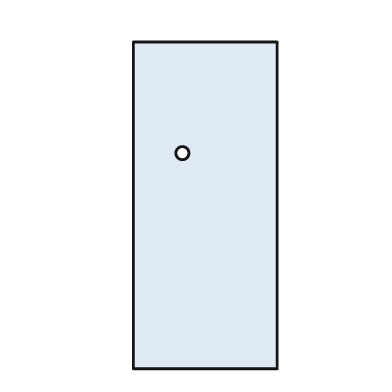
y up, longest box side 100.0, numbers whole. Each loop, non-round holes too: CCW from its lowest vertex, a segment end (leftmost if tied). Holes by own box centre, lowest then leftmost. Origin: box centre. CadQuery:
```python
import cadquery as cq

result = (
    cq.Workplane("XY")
    .moveTo(-22.0, -50.0)
    .lineTo(22.0, -50.0)
    .lineTo(22.0, 50.0)
    .lineTo(-22.0, 50.0)
    .close()
    .moveTo(-7.0, 16.0)
    .circle(2.0)
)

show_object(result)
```